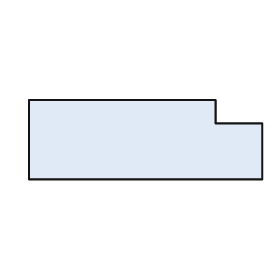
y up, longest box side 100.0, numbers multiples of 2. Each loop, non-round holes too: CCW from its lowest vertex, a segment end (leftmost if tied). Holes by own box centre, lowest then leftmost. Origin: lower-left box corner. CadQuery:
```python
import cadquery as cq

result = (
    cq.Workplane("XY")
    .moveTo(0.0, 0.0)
    .lineTo(100.0, 0.0)
    .lineTo(100.0, 24.0)
    .lineTo(80.0, 24.0)
    .lineTo(80.0, 34.0)
    .lineTo(0.0, 34.0)
    .close()
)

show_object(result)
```